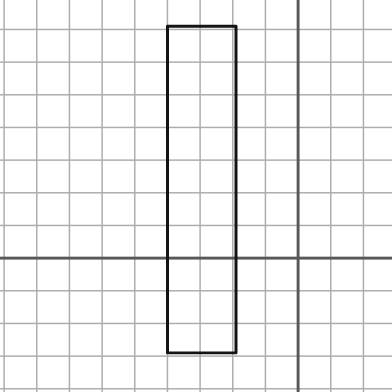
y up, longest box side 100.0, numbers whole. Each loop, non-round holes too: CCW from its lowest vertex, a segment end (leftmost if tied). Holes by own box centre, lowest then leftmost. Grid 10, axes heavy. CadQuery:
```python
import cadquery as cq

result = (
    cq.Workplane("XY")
    .moveTo(-40.0, -29.0)
    .lineTo(-19.0, -29.0)
    .lineTo(-19.0, 71.0)
    .lineTo(-40.0, 71.0)
    .close()
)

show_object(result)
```